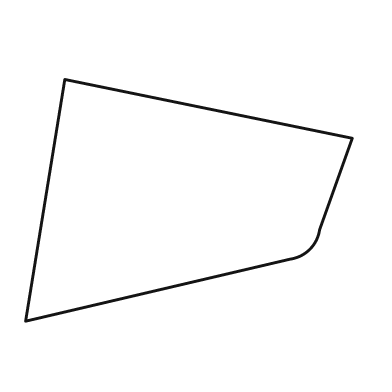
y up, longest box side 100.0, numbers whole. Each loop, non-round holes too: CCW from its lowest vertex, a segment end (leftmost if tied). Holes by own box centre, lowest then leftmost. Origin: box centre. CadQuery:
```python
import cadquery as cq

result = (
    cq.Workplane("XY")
    .moveTo(-50.0, -37.0)
    .lineTo(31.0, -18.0)
    .threePointArc((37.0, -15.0), (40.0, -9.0))
    .lineTo(50.0, 19.0)
    .lineTo(-38.0, 37.0)
    .close()
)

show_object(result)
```